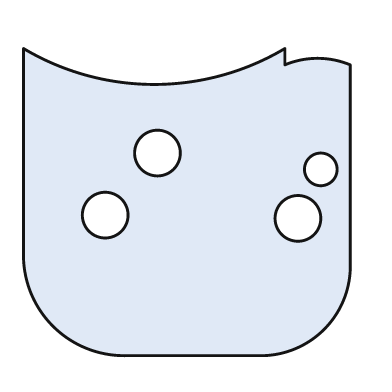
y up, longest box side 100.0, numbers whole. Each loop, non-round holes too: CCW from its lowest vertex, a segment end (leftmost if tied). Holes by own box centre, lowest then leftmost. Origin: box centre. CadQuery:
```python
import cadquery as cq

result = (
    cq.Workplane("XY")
    .moveTo(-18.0, -47.0)
    .lineTo(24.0, -47.0)
    .threePointArc((42.0, -39.0), (50.0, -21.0))
    .lineTo(50.0, 42.0)
    .threePointArc((40.0, 44.0), (30.0, 42.0))
    .lineTo(30.0, 47.0)
    .threePointArc((-10.0, 36.0), (-50.0, 47.0))
    .lineTo(-50.0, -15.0)
    .threePointArc((-41.0, -38.0), (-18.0, -47.0))
    .close()
    .moveTo(34.0, -5.0)
    .circle(7.0)
    .moveTo(-25.0, -4.0)
    .circle(7.0)
    .moveTo(41.0, 10.0)
    .circle(5.0)
    .moveTo(-9.0, 15.0)
    .circle(7.0)
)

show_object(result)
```